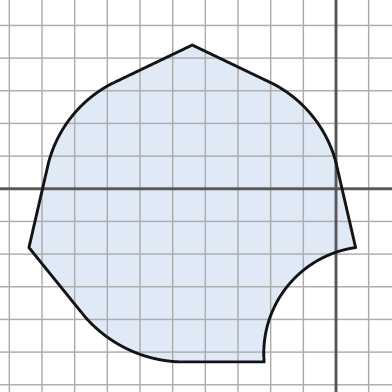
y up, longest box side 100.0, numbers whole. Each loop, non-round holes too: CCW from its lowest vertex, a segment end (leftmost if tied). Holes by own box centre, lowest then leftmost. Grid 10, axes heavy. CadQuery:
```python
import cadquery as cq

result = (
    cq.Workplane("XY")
    .moveTo(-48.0, -53.0)
    .lineTo(-22.0, -53.0)
    .threePointArc((-15.0, -30.0), (6.0, -18.0))
    .lineTo(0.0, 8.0)
    .threePointArc((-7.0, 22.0), (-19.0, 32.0))
    .lineTo(-44.0, 44.0)
    .lineTo(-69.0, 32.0)
    .threePointArc((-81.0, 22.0), (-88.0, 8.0))
    .lineTo(-94.0, -18.0)
    .lineTo(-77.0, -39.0)
    .threePointArc((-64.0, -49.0), (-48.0, -53.0))
    .close()
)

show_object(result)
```